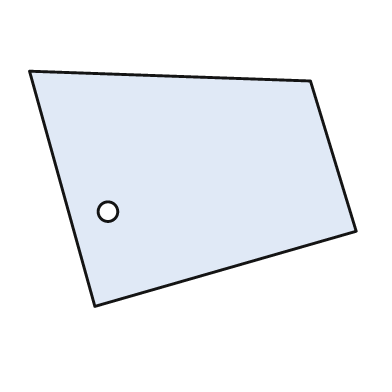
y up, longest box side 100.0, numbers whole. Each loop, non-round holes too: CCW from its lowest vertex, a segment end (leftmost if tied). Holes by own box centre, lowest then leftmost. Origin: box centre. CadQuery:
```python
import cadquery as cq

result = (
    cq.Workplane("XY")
    .moveTo(-30.0, -36.0)
    .lineTo(50.0, -13.0)
    .lineTo(36.0, 33.0)
    .lineTo(-50.0, 36.0)
    .close()
    .moveTo(-26.0, -7.0)
    .circle(3.0)
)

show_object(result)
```